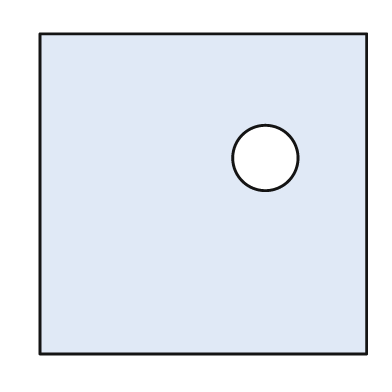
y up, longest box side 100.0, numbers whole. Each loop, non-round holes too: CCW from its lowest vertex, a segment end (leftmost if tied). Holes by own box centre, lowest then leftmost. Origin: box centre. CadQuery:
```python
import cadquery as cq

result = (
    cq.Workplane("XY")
    .moveTo(-50.0, -49.0)
    .lineTo(50.0, -49.0)
    .lineTo(50.0, 49.0)
    .lineTo(-50.0, 49.0)
    .close()
    .moveTo(19.0, 11.0)
    .circle(10.0)
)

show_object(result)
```